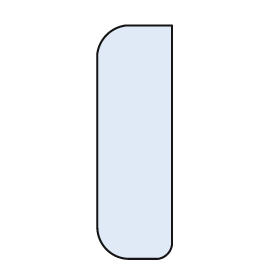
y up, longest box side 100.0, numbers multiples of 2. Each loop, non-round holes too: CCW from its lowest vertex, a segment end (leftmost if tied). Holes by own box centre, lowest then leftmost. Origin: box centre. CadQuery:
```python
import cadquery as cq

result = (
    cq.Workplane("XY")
    .moveTo(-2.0, -50.0)
    .lineTo(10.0, -50.0)
    .threePointArc((14.0, -48.0), (16.0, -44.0))
    .lineTo(16.0, 50.0)
    .lineTo(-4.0, 50.0)
    .threePointArc((-12.0, 46.0), (-16.0, 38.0))
    .lineTo(-16.0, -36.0)
    .threePointArc((-12.0, -46.0), (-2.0, -50.0))
    .close()
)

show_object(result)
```